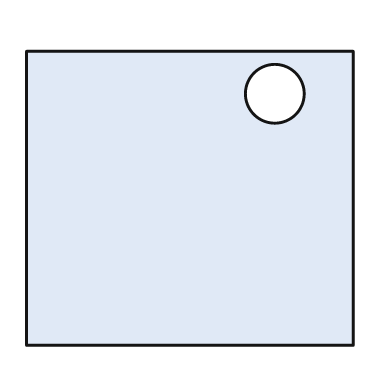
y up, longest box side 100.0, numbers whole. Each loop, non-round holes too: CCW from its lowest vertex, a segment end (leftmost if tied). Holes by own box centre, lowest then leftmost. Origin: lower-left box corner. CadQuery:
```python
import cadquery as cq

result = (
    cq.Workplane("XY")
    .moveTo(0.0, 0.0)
    .lineTo(100.0, 0.0)
    .lineTo(100.0, 90.0)
    .lineTo(0.0, 90.0)
    .close()
    .moveTo(76.0, 77.0)
    .circle(9.0)
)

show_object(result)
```